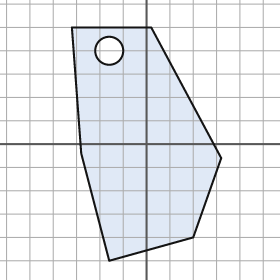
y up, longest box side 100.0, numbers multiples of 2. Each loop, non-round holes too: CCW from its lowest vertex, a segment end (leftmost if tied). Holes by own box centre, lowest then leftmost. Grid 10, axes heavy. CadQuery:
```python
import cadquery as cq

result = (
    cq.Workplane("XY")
    .moveTo(-16.0, -50.0)
    .lineTo(20.0, -40.0)
    .lineTo(32.0, -6.0)
    .lineTo(2.0, 50.0)
    .lineTo(-32.0, 50.0)
    .lineTo(-28.0, -4.0)
    .close()
    .moveTo(-16.0, 40.0)
    .circle(6.0)
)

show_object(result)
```